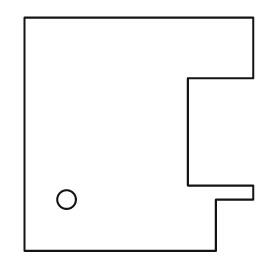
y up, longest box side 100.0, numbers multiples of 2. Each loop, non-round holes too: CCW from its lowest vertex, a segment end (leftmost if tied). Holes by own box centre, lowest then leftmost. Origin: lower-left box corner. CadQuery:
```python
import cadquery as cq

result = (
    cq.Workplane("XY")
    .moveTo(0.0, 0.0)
    .lineTo(82.0, 0.0)
    .lineTo(82.0, 22.0)
    .lineTo(98.0, 22.0)
    .lineTo(98.0, 28.0)
    .lineTo(70.0, 28.0)
    .lineTo(70.0, 74.0)
    .lineTo(98.0, 74.0)
    .lineTo(98.0, 100.0)
    .lineTo(0.0, 100.0)
    .close()
    .moveTo(18.0, 22.0)
    .circle(4.0)
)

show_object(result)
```